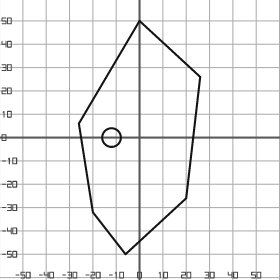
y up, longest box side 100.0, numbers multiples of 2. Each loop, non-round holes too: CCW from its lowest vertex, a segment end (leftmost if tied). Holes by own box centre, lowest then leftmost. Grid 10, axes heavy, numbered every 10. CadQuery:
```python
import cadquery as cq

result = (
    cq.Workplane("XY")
    .moveTo(-6.0, -50.0)
    .lineTo(20.0, -26.0)
    .lineTo(26.0, 26.0)
    .lineTo(0.0, 50.0)
    .lineTo(-26.0, 6.0)
    .lineTo(-20.0, -32.0)
    .close()
    .moveTo(-12.0, 0.0)
    .circle(4.0)
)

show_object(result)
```